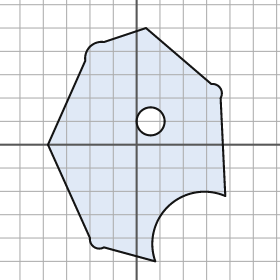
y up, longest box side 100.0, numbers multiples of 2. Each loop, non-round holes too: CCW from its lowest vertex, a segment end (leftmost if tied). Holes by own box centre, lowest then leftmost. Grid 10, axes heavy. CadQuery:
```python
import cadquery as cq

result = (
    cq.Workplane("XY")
    .moveTo(8.0, -50.0)
    .threePointArc((14.0, -26.0), (38.0, -22.0))
    .lineTo(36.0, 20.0)
    .threePointArc((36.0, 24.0), (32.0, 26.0))
    .lineTo(4.0, 50.0)
    .lineTo(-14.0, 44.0)
    .threePointArc((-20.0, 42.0), (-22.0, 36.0))
    .lineTo(-38.0, 0.0)
    .lineTo(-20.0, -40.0)
    .threePointArc((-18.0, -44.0), (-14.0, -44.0))
    .close()
    .moveTo(6.0, 10.0)
    .circle(6.0)
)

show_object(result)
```